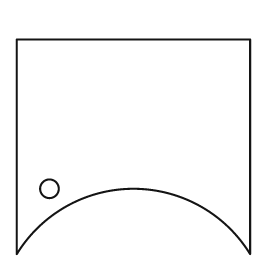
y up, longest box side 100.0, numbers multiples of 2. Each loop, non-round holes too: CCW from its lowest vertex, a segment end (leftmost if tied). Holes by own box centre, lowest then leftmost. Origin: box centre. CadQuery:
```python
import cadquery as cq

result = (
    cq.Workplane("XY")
    .moveTo(-50.0, -46.0)
    .threePointArc((0.0, -18.0), (50.0, -46.0))
    .lineTo(50.0, 46.0)
    .lineTo(-50.0, 46.0)
    .close()
    .moveTo(-36.0, -18.0)
    .circle(4.0)
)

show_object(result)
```